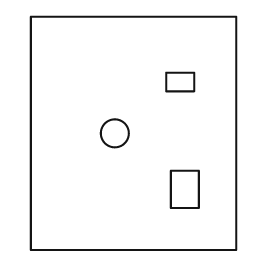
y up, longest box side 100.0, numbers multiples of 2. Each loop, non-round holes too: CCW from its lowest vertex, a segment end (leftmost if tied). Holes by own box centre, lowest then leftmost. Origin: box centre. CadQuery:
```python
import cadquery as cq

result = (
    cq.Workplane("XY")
    .moveTo(-44.0, -50.0)
    .lineTo(44.0, -50.0)
    .lineTo(44.0, 50.0)
    .lineTo(-44.0, 50.0)
    .close()
    .moveTo(16.0, -32.0)
    .lineTo(28.0, -32.0)
    .lineTo(28.0, -16.0)
    .lineTo(16.0, -16.0)
    .close()
    .moveTo(-8.0, 0.0)
    .circle(6.0)
    .moveTo(14.0, 18.0)
    .lineTo(26.0, 18.0)
    .lineTo(26.0, 26.0)
    .lineTo(14.0, 26.0)
    .close()
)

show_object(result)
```